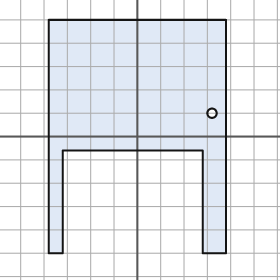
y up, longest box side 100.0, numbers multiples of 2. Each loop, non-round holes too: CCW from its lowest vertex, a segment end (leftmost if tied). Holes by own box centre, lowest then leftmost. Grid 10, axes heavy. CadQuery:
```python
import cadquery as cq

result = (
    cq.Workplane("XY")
    .moveTo(-38.0, -50.0)
    .lineTo(-32.0, -50.0)
    .lineTo(-32.0, -6.0)
    .lineTo(28.0, -6.0)
    .lineTo(28.0, -50.0)
    .lineTo(38.0, -50.0)
    .lineTo(38.0, 50.0)
    .lineTo(-38.0, 50.0)
    .close()
    .moveTo(32.0, 10.0)
    .circle(2.0)
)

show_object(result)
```